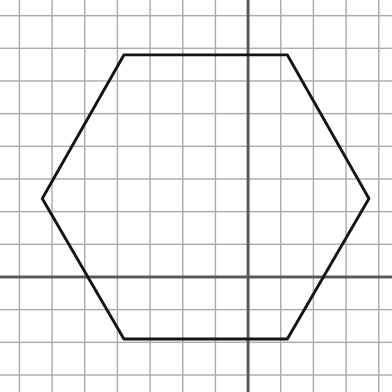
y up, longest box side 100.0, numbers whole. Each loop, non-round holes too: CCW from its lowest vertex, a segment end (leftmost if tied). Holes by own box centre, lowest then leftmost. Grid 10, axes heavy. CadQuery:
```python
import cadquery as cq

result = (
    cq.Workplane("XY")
    .moveTo(-38.0, -19.0)
    .lineTo(12.0, -19.0)
    .lineTo(37.0, 24.0)
    .lineTo(12.0, 68.0)
    .lineTo(-38.0, 68.0)
    .lineTo(-63.0, 24.0)
    .close()
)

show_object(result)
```